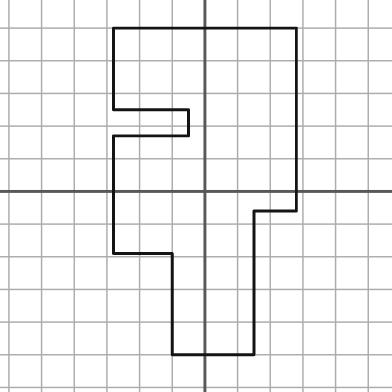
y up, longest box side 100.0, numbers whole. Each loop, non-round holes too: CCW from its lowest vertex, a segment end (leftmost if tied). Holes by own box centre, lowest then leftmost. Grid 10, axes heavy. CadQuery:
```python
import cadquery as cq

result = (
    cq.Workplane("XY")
    .moveTo(-10.0, -50.0)
    .lineTo(15.0, -50.0)
    .lineTo(15.0, -6.0)
    .lineTo(28.0, -6.0)
    .lineTo(28.0, 50.0)
    .lineTo(-28.0, 50.0)
    .lineTo(-28.0, 25.0)
    .lineTo(-5.0, 25.0)
    .lineTo(-5.0, 17.0)
    .lineTo(-28.0, 17.0)
    .lineTo(-28.0, -19.0)
    .lineTo(-10.0, -19.0)
    .close()
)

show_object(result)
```